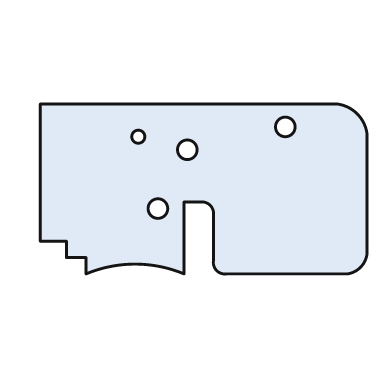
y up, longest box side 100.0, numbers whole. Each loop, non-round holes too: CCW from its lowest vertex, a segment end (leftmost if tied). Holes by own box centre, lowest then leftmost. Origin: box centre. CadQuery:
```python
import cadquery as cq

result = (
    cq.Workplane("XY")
    .moveTo(-36.0, -26.0)
    .threePointArc((-21.0, -23.0), (-6.0, -26.0))
    .lineTo(-6.0, -4.0)
    .lineTo(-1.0, -4.0)
    .threePointArc((2.0, -5.0), (3.0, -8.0))
    .lineTo(3.0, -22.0)
    .threePointArc((4.0, -25.0), (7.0, -26.0))
    .lineTo(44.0, -26.0)
    .threePointArc((48.0, -24.0), (50.0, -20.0))
    .lineTo(50.0, 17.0)
    .threePointArc((47.0, 23.0), (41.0, 26.0))
    .lineTo(-50.0, 26.0)
    .lineTo(-50.0, -16.0)
    .lineTo(-42.0, -16.0)
    .lineTo(-42.0, -21.0)
    .lineTo(-36.0, -21.0)
    .close()
    .moveTo(-14.0, -6.0)
    .circle(3.0)
    .moveTo(-5.0, 12.0)
    .circle(3.0)
    .moveTo(-20.0, 16.0)
    .circle(2.0)
    .moveTo(25.0, 19.0)
    .circle(3.0)
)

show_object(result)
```